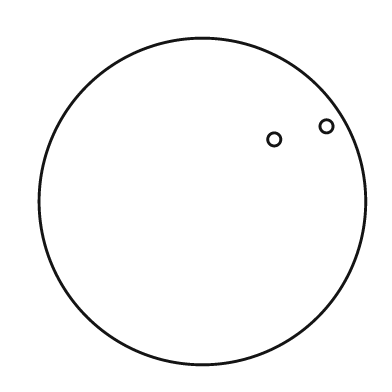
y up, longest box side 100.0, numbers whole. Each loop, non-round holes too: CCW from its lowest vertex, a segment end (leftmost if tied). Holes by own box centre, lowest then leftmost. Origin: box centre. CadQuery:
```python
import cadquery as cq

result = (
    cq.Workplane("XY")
    .moveTo(0.0, 0.0)
    .circle(50.0)
    .moveTo(22.0, 19.0)
    .circle(2.0)
    .moveTo(38.0, 23.0)
    .circle(2.0)
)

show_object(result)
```